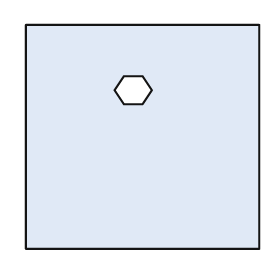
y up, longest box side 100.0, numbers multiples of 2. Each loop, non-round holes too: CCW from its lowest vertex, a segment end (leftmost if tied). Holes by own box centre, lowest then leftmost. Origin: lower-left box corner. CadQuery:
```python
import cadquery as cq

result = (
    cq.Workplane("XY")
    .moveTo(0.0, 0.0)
    .lineTo(100.0, 0.0)
    .lineTo(100.0, 96.0)
    .lineTo(0.0, 96.0)
    .close()
    .moveTo(42.0, 62.0)
    .lineTo(50.0, 62.0)
    .lineTo(54.0, 68.0)
    .lineTo(50.0, 74.0)
    .lineTo(42.0, 74.0)
    .lineTo(38.0, 68.0)
    .close()
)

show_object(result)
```